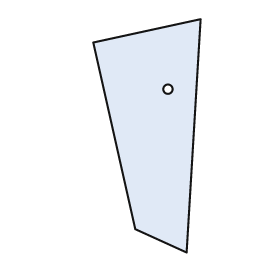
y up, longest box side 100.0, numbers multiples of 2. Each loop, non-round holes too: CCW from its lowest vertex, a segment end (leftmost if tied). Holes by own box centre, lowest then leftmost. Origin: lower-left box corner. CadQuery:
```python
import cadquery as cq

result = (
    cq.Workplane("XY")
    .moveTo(40.0, 0.0)
    .lineTo(46.0, 100.0)
    .lineTo(0.0, 90.0)
    .lineTo(18.0, 10.0)
    .close()
    .moveTo(32.0, 70.0)
    .circle(2.0)
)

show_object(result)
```